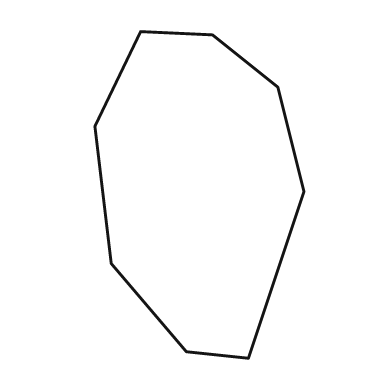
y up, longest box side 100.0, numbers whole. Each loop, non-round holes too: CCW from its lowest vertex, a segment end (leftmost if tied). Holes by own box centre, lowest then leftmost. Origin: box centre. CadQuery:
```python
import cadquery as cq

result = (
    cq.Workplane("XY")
    .moveTo(15.0, -50.0)
    .lineTo(32.0, 1.0)
    .lineTo(24.0, 33.0)
    .lineTo(4.0, 49.0)
    .lineTo(-18.0, 50.0)
    .lineTo(-32.0, 21.0)
    .lineTo(-27.0, -21.0)
    .lineTo(-4.0, -48.0)
    .close()
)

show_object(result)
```